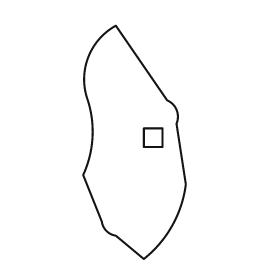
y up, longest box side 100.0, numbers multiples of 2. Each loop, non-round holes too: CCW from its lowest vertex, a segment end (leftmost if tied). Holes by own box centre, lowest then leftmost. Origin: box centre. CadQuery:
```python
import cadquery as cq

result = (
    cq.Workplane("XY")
    .moveTo(4.0, -50.0)
    .threePointArc((16.0, -36.0), (22.0, -18.0))
    .lineTo(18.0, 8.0)
    .threePointArc((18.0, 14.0), (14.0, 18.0))
    .lineTo(-8.0, 50.0)
    .threePointArc((-20.0, 36.0), (-20.0, 18.0))
    .threePointArc((-18.0, 2.0), (-22.0, -14.0))
    .lineTo(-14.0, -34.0)
    .threePointArc((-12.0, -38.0), (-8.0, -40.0))
    .close()
    .moveTo(4.0, -2.0)
    .lineTo(12.0, -2.0)
    .lineTo(12.0, 6.0)
    .lineTo(4.0, 6.0)
    .close()
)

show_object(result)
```